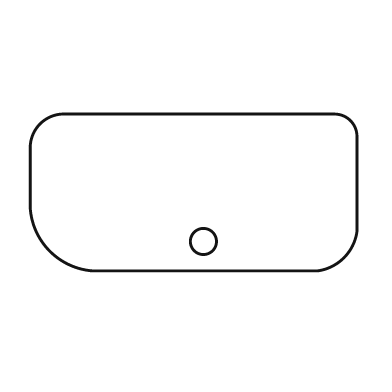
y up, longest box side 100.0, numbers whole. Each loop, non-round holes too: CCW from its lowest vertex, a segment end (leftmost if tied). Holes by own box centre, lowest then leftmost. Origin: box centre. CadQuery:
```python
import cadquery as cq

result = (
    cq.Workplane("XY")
    .moveTo(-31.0, -24.0)
    .lineTo(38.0, -24.0)
    .threePointArc((46.0, -20.0), (50.0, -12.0))
    .lineTo(50.0, 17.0)
    .threePointArc((48.0, 22.0), (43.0, 24.0))
    .lineTo(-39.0, 24.0)
    .threePointArc((-47.0, 21.0), (-50.0, 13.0))
    .lineTo(-50.0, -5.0)
    .threePointArc((-44.0, -18.0), (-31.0, -24.0))
    .close()
    .moveTo(3.0, -15.0)
    .circle(4.0)
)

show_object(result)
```